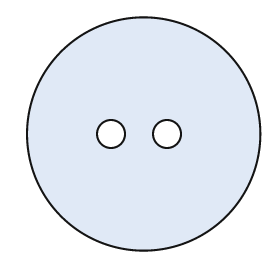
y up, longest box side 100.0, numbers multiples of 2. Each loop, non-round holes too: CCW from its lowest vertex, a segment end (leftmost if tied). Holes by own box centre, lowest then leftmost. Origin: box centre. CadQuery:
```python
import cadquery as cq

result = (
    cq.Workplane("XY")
    .moveTo(0.0, 0.0)
    .circle(50.0)
    .moveTo(-14.0, 0.0)
    .circle(6.0)
    .moveTo(10.0, 0.0)
    .circle(6.0)
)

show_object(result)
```